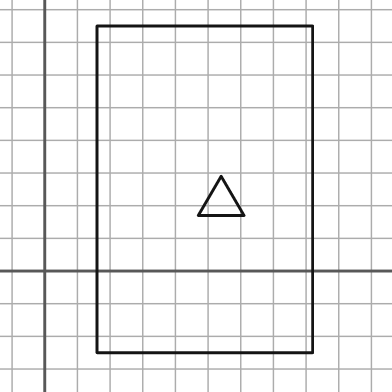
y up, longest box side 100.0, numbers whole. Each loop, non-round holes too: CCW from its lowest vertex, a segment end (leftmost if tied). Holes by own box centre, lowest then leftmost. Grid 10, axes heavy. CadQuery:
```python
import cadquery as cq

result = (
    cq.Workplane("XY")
    .moveTo(16.0, -25.0)
    .lineTo(82.0, -25.0)
    .lineTo(82.0, 75.0)
    .lineTo(16.0, 75.0)
    .close()
    .moveTo(47.0, 17.0)
    .lineTo(61.0, 17.0)
    .lineTo(54.0, 29.0)
    .close()
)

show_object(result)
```